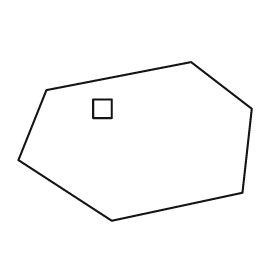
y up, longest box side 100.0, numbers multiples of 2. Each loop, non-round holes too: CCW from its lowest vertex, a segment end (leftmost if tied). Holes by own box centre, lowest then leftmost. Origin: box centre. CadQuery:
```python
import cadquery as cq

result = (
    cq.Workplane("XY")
    .moveTo(-10.0, -34.0)
    .lineTo(46.0, -22.0)
    .lineTo(50.0, 14.0)
    .lineTo(24.0, 34.0)
    .lineTo(-38.0, 22.0)
    .lineTo(-50.0, -8.0)
    .close()
    .moveTo(-18.0, 10.0)
    .lineTo(-10.0, 10.0)
    .lineTo(-10.0, 18.0)
    .lineTo(-18.0, 18.0)
    .close()
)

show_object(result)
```